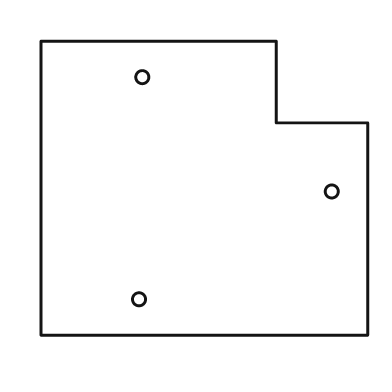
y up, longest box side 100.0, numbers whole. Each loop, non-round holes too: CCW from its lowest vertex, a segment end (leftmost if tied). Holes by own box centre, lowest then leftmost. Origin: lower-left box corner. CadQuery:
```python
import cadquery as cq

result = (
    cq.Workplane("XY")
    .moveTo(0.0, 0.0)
    .lineTo(100.0, 0.0)
    .lineTo(100.0, 65.0)
    .lineTo(72.0, 65.0)
    .lineTo(72.0, 90.0)
    .lineTo(0.0, 90.0)
    .close()
    .moveTo(30.0, 11.0)
    .circle(2.0)
    .moveTo(89.0, 44.0)
    .circle(2.0)
    .moveTo(31.0, 79.0)
    .circle(2.0)
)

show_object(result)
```